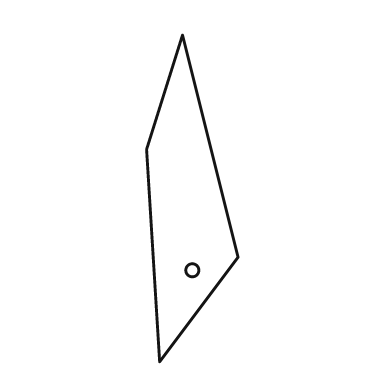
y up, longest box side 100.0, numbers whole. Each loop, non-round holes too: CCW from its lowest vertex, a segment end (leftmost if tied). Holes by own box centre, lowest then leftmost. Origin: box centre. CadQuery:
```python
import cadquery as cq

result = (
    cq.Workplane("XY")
    .moveTo(-10.0, -50.0)
    .lineTo(14.0, -18.0)
    .lineTo(-3.0, 50.0)
    .lineTo(-14.0, 15.0)
    .close()
    .moveTo(0.0, -22.0)
    .circle(2.0)
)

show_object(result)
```